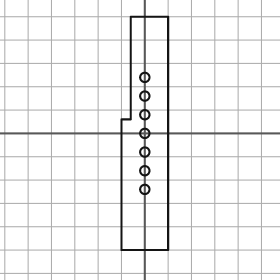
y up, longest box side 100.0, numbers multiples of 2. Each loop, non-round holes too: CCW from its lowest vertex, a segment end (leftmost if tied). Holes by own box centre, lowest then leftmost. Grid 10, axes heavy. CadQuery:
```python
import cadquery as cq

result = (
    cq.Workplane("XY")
    .moveTo(-10.0, -50.0)
    .lineTo(10.0, -50.0)
    .lineTo(10.0, 50.0)
    .lineTo(-6.0, 50.0)
    .lineTo(-6.0, 6.0)
    .lineTo(-10.0, 6.0)
    .close()
    .moveTo(0.0, -24.0)
    .circle(2.0)
    .moveTo(0.0, -16.0)
    .circle(2.0)
    .moveTo(0.0, -8.0)
    .circle(2.0)
    .moveTo(0.0, 0.0)
    .circle(2.0)
    .moveTo(0.0, 8.0)
    .circle(2.0)
    .moveTo(0.0, 16.0)
    .circle(2.0)
    .moveTo(0.0, 24.0)
    .circle(2.0)
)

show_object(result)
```